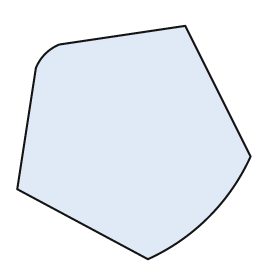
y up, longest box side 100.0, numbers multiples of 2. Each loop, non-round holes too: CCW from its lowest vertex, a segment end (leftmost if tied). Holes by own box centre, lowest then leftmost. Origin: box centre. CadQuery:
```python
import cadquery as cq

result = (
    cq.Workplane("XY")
    .moveTo(6.0, -50.0)
    .threePointArc((32.0, -32.0), (50.0, -6.0))
    .lineTo(22.0, 50.0)
    .lineTo(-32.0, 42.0)
    .threePointArc((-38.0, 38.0), (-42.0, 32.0))
    .lineTo(-50.0, -20.0)
    .close()
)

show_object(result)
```